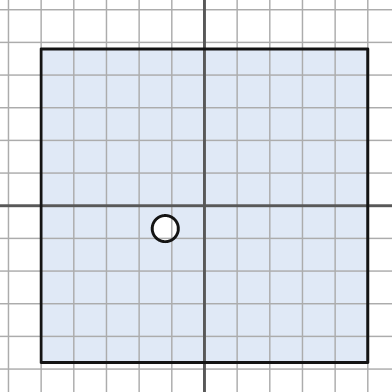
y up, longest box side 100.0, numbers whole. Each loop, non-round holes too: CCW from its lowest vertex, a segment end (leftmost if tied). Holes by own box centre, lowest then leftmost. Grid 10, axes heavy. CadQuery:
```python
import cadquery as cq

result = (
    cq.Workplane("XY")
    .moveTo(-50.0, -48.0)
    .lineTo(50.0, -48.0)
    .lineTo(50.0, 48.0)
    .lineTo(-50.0, 48.0)
    .close()
    .moveTo(-12.0, -7.0)
    .circle(4.0)
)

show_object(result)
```